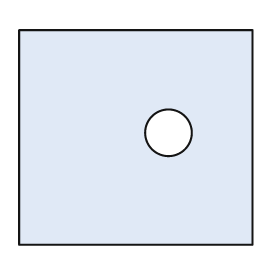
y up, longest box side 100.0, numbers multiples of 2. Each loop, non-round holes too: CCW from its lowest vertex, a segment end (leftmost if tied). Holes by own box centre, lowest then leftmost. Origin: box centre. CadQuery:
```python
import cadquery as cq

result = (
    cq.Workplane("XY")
    .moveTo(-50.0, -46.0)
    .lineTo(50.0, -46.0)
    .lineTo(50.0, 46.0)
    .lineTo(-50.0, 46.0)
    .close()
    .moveTo(14.0, 2.0)
    .circle(10.0)
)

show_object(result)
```